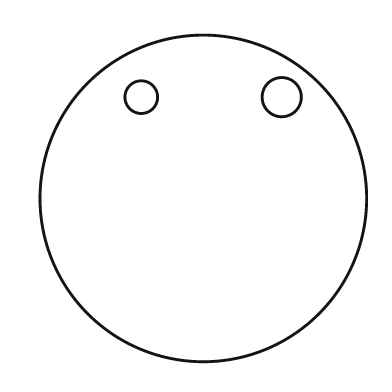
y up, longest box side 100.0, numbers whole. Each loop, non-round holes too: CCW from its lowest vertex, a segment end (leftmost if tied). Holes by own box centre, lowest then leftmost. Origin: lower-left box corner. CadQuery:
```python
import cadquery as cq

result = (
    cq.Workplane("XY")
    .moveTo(50.0, 50.0)
    .circle(50.0)
    .moveTo(31.0, 81.0)
    .circle(5.0)
    .moveTo(74.0, 81.0)
    .circle(6.0)
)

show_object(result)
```